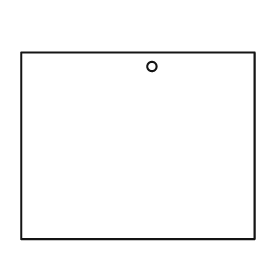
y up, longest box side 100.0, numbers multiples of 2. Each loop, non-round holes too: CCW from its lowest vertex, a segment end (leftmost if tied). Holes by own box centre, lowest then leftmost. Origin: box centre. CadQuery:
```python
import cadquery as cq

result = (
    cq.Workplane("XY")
    .moveTo(-50.0, -40.0)
    .lineTo(50.0, -40.0)
    .lineTo(50.0, 40.0)
    .lineTo(-50.0, 40.0)
    .close()
    .moveTo(6.0, 34.0)
    .circle(2.0)
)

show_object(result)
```